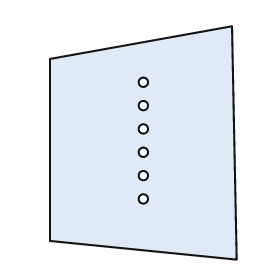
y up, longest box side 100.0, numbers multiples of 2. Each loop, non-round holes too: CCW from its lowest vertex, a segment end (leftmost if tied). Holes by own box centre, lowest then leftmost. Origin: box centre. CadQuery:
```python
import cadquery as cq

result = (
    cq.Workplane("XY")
    .moveTo(40.0, -50.0)
    .lineTo(38.0, 50.0)
    .lineTo(-40.0, 36.0)
    .lineTo(-40.0, -42.0)
    .close()
    .moveTo(0.0, -24.0)
    .circle(2.0)
    .moveTo(0.0, -14.0)
    .circle(2.0)
    .moveTo(0.0, -4.0)
    .circle(2.0)
    .moveTo(0.0, 6.0)
    .circle(2.0)
    .moveTo(0.0, 16.0)
    .circle(2.0)
    .moveTo(0.0, 26.0)
    .circle(2.0)
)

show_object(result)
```